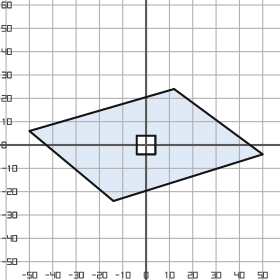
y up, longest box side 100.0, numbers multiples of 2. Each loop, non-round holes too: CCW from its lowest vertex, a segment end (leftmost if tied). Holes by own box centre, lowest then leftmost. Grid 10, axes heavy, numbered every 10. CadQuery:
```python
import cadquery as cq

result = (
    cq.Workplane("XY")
    .moveTo(-14.0, -24.0)
    .lineTo(50.0, -4.0)
    .lineTo(12.0, 24.0)
    .lineTo(-50.0, 6.0)
    .close()
    .moveTo(-4.0, -4.0)
    .lineTo(4.0, -4.0)
    .lineTo(4.0, 4.0)
    .lineTo(-4.0, 4.0)
    .close()
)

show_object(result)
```